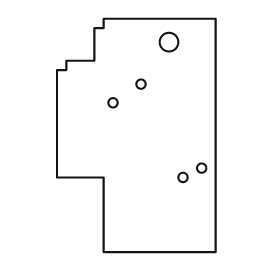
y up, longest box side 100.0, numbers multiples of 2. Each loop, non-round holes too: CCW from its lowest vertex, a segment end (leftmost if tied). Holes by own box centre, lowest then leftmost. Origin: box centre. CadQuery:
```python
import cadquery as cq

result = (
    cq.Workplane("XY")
    .moveTo(-14.0, -50.0)
    .lineTo(34.0, -50.0)
    .lineTo(34.0, 50.0)
    .lineTo(-14.0, 50.0)
    .lineTo(-14.0, 46.0)
    .lineTo(-18.0, 46.0)
    .lineTo(-18.0, 32.0)
    .lineTo(-30.0, 32.0)
    .lineTo(-30.0, 28.0)
    .lineTo(-34.0, 28.0)
    .lineTo(-34.0, -18.0)
    .lineTo(-14.0, -18.0)
    .close()
    .moveTo(20.0, -18.0)
    .circle(2.0)
    .moveTo(28.0, -14.0)
    .circle(2.0)
    .moveTo(-10.0, 14.0)
    .circle(2.0)
    .moveTo(2.0, 22.0)
    .circle(2.0)
    .moveTo(14.0, 40.0)
    .circle(4.0)
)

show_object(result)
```